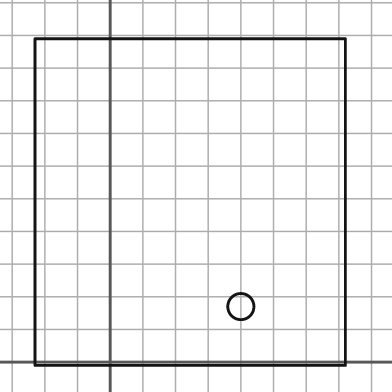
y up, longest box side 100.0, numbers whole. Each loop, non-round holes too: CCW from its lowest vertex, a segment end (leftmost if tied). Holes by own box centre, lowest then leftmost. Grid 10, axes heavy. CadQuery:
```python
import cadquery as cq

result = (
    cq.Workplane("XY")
    .moveTo(-23.0, -1.0)
    .lineTo(72.0, -1.0)
    .lineTo(72.0, 99.0)
    .lineTo(-23.0, 99.0)
    .close()
    .moveTo(40.0, 17.0)
    .circle(4.0)
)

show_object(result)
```